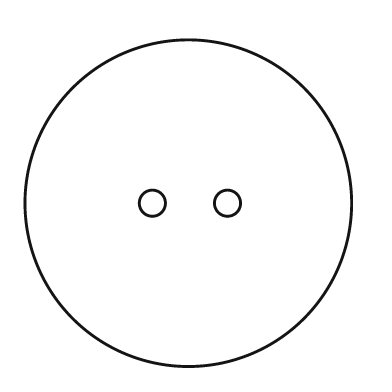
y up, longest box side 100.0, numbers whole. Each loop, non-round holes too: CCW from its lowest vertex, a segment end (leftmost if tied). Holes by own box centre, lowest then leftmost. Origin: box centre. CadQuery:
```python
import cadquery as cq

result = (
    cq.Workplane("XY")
    .moveTo(0.0, 0.0)
    .circle(50.0)
    .moveTo(-11.0, 0.0)
    .circle(4.0)
    .moveTo(12.0, 0.0)
    .circle(4.0)
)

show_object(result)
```